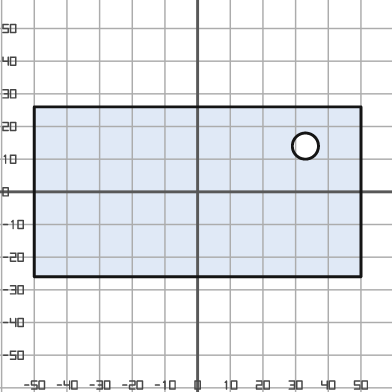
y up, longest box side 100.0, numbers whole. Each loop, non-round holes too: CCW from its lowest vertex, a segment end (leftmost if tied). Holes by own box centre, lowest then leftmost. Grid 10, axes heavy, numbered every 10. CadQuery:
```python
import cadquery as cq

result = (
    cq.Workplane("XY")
    .moveTo(-50.0, -26.0)
    .lineTo(50.0, -26.0)
    .lineTo(50.0, 26.0)
    .lineTo(-50.0, 26.0)
    .close()
    .moveTo(33.0, 14.0)
    .circle(4.0)
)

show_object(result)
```